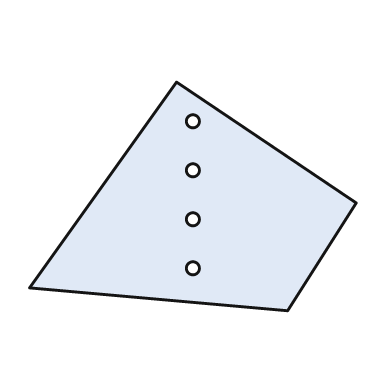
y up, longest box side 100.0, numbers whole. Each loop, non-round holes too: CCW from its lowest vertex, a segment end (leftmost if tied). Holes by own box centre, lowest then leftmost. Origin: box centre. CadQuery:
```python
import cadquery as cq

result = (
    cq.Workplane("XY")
    .moveTo(29.0, -35.0)
    .lineTo(50.0, -2.0)
    .lineTo(-5.0, 35.0)
    .lineTo(-50.0, -28.0)
    .close()
    .moveTo(0.0, -22.0)
    .circle(2.0)
    .moveTo(0.0, -7.0)
    .circle(2.0)
    .moveTo(0.0, 8.0)
    .circle(2.0)
    .moveTo(0.0, 23.0)
    .circle(2.0)
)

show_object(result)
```